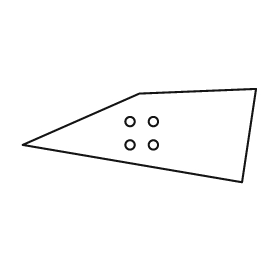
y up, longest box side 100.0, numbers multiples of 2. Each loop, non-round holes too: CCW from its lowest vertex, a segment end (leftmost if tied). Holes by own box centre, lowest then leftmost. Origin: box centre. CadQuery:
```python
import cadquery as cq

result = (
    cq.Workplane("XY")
    .moveTo(44.0, -20.0)
    .lineTo(50.0, 20.0)
    .lineTo(0.0, 18.0)
    .lineTo(-50.0, -4.0)
    .close()
    .moveTo(-4.0, -4.0)
    .circle(2.0)
    .moveTo(6.0, -4.0)
    .circle(2.0)
    .moveTo(-4.0, 6.0)
    .circle(2.0)
    .moveTo(6.0, 6.0)
    .circle(2.0)
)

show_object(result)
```